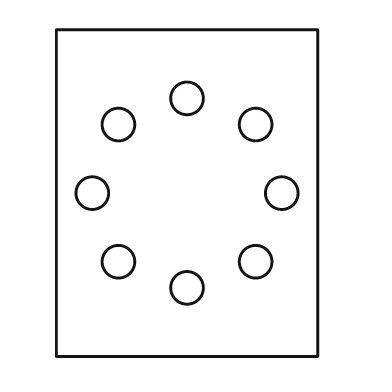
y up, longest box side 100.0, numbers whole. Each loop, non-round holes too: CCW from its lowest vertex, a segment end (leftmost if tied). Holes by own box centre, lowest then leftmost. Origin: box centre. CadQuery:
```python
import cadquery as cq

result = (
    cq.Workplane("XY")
    .moveTo(-40.0, -50.0)
    .lineTo(40.0, -50.0)
    .lineTo(40.0, 50.0)
    .lineTo(-40.0, 50.0)
    .close()
    .moveTo(0.0, -29.0)
    .circle(5.0)
    .moveTo(-21.0, -21.0)
    .circle(5.0)
    .moveTo(21.0, -21.0)
    .circle(5.0)
    .moveTo(-29.0, 0.0)
    .circle(5.0)
    .moveTo(29.0, 0.0)
    .circle(5.0)
    .moveTo(-21.0, 21.0)
    .circle(5.0)
    .moveTo(21.0, 21.0)
    .circle(5.0)
    .moveTo(0.0, 29.0)
    .circle(5.0)
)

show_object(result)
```